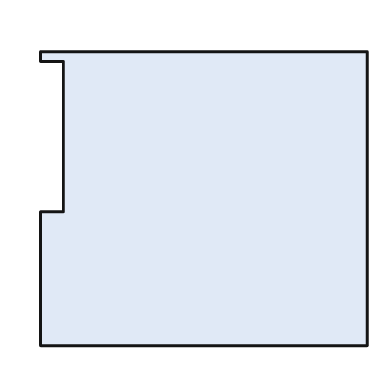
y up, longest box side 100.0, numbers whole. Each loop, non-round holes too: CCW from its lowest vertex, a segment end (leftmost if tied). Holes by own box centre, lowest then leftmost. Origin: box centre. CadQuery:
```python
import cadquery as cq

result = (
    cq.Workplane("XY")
    .moveTo(-50.0, -45.0)
    .lineTo(50.0, -45.0)
    .lineTo(50.0, 45.0)
    .lineTo(-50.0, 45.0)
    .lineTo(-50.0, 42.0)
    .lineTo(-43.0, 42.0)
    .lineTo(-43.0, -4.0)
    .lineTo(-50.0, -4.0)
    .close()
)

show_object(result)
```